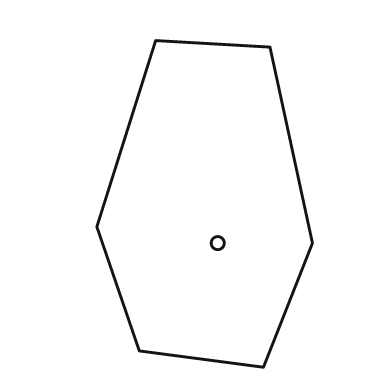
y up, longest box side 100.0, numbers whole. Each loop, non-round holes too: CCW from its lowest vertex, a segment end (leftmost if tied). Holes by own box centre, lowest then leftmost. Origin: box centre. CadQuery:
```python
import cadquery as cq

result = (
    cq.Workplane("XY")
    .moveTo(18.0, -50.0)
    .lineTo(33.0, -12.0)
    .lineTo(20.0, 48.0)
    .lineTo(-15.0, 50.0)
    .lineTo(-33.0, -7.0)
    .lineTo(-20.0, -45.0)
    .close()
    .moveTo(4.0, -12.0)
    .circle(2.0)
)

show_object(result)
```